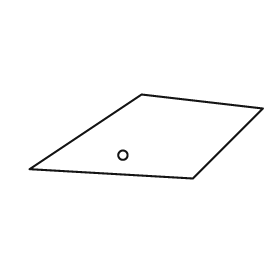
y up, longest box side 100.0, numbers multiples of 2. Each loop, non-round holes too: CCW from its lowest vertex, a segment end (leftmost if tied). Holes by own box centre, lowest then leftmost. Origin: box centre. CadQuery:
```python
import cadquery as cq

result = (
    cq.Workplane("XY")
    .moveTo(20.0, -18.0)
    .lineTo(50.0, 12.0)
    .lineTo(-2.0, 18.0)
    .lineTo(-50.0, -14.0)
    .close()
    .moveTo(-10.0, -8.0)
    .circle(2.0)
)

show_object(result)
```